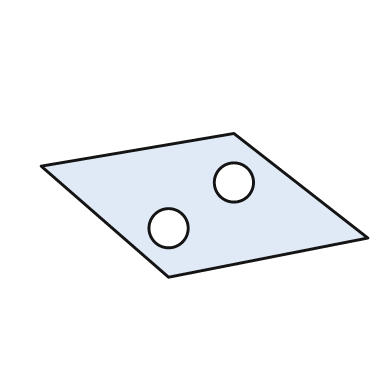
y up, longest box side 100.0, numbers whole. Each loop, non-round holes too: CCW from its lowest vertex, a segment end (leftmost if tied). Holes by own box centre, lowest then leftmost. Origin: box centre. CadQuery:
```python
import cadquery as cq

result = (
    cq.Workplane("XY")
    .moveTo(-11.0, -22.0)
    .lineTo(50.0, -10.0)
    .lineTo(9.0, 22.0)
    .lineTo(-50.0, 12.0)
    .close()
    .moveTo(-11.0, -7.0)
    .circle(6.0)
    .moveTo(9.0, 7.0)
    .circle(6.0)
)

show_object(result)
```